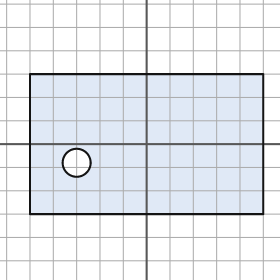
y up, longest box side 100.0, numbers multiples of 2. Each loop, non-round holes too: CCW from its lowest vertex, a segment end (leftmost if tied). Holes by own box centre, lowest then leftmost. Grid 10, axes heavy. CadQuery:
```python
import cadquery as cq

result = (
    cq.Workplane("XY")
    .moveTo(-50.0, -30.0)
    .lineTo(50.0, -30.0)
    .lineTo(50.0, 30.0)
    .lineTo(-50.0, 30.0)
    .close()
    .moveTo(-30.0, -8.0)
    .circle(6.0)
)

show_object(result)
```